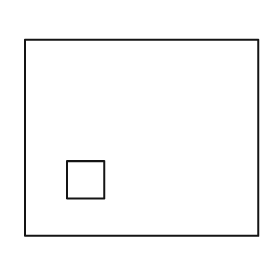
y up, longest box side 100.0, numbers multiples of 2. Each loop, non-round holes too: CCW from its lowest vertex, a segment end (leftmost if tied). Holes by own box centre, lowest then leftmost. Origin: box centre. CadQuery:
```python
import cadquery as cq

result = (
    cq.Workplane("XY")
    .moveTo(-50.0, -42.0)
    .lineTo(50.0, -42.0)
    .lineTo(50.0, 42.0)
    .lineTo(-50.0, 42.0)
    .close()
    .moveTo(-32.0, -26.0)
    .lineTo(-16.0, -26.0)
    .lineTo(-16.0, -10.0)
    .lineTo(-32.0, -10.0)
    .close()
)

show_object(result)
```